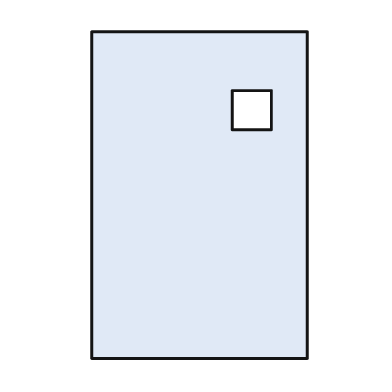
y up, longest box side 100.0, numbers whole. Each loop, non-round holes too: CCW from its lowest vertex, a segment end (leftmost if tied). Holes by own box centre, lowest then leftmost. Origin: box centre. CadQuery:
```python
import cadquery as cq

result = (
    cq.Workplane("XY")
    .moveTo(-33.0, -50.0)
    .lineTo(33.0, -50.0)
    .lineTo(33.0, 50.0)
    .lineTo(-33.0, 50.0)
    .close()
    .moveTo(10.0, 20.0)
    .lineTo(22.0, 20.0)
    .lineTo(22.0, 32.0)
    .lineTo(10.0, 32.0)
    .close()
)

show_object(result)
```